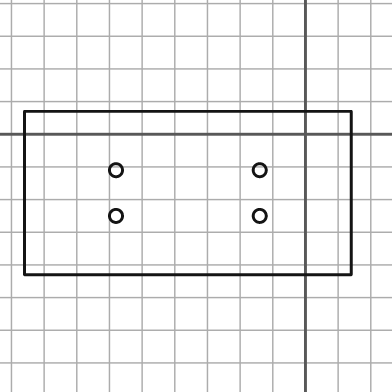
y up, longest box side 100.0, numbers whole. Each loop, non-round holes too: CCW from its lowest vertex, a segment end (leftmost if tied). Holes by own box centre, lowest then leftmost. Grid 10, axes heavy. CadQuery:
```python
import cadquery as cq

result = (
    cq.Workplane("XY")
    .moveTo(-86.0, -43.0)
    .lineTo(14.0, -43.0)
    .lineTo(14.0, 7.0)
    .lineTo(-86.0, 7.0)
    .close()
    .moveTo(-58.0, -25.0)
    .circle(2.0)
    .moveTo(-14.0, -25.0)
    .circle(2.0)
    .moveTo(-58.0, -11.0)
    .circle(2.0)
    .moveTo(-14.0, -11.0)
    .circle(2.0)
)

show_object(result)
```